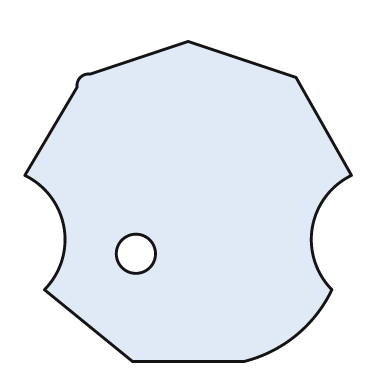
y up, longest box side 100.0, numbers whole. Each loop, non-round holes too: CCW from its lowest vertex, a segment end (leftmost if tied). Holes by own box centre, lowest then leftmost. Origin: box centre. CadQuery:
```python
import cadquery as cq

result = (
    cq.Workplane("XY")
    .moveTo(-17.0, -49.0)
    .lineTo(17.0, -49.0)
    .threePointArc((33.0, -41.0), (44.0, -27.0))
    .threePointArc((38.0, -8.0), (50.0, 8.0))
    .lineTo(33.0, 38.0)
    .lineTo(0.0, 49.0)
    .lineTo(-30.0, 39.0)
    .threePointArc((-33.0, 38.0), (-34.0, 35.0))
    .lineTo(-50.0, 8.0)
    .threePointArc((-38.0, -8.0), (-44.0, -27.0))
    .close()
    .moveTo(-16.0, -16.0)
    .circle(6.0)
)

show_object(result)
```